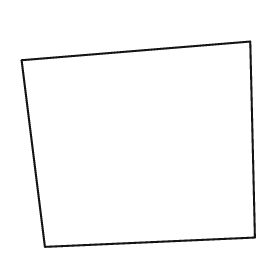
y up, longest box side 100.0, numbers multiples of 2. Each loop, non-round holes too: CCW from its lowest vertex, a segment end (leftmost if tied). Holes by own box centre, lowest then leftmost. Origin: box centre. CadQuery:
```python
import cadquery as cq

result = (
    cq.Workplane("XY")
    .moveTo(-40.0, -44.0)
    .lineTo(50.0, -40.0)
    .lineTo(48.0, 44.0)
    .lineTo(-50.0, 36.0)
    .close()
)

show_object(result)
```